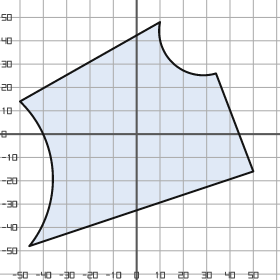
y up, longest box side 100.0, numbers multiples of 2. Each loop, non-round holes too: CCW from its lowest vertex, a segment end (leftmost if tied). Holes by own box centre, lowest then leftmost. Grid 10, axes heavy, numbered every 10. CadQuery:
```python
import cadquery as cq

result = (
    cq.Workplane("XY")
    .moveTo(-46.0, -48.0)
    .lineTo(50.0, -16.0)
    .lineTo(34.0, 26.0)
    .threePointArc((16.0, 30.0), (10.0, 48.0))
    .lineTo(-50.0, 14.0)
    .threePointArc((-36.0, -16.0), (-46.0, -48.0))
    .close()
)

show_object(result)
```